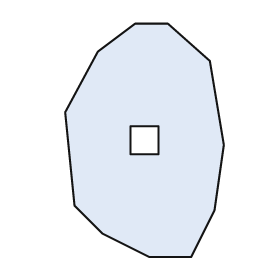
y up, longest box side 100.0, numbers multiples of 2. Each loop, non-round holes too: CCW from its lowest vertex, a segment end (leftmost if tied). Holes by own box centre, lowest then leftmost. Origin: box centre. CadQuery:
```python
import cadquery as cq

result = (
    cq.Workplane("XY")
    .moveTo(2.0, -50.0)
    .lineTo(20.0, -50.0)
    .lineTo(30.0, -30.0)
    .lineTo(34.0, -2.0)
    .lineTo(28.0, 34.0)
    .lineTo(10.0, 50.0)
    .lineTo(-4.0, 50.0)
    .lineTo(-20.0, 38.0)
    .lineTo(-34.0, 12.0)
    .lineTo(-30.0, -28.0)
    .lineTo(-18.0, -40.0)
    .close()
    .moveTo(-6.0, -6.0)
    .lineTo(6.0, -6.0)
    .lineTo(6.0, 6.0)
    .lineTo(-6.0, 6.0)
    .close()
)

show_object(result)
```